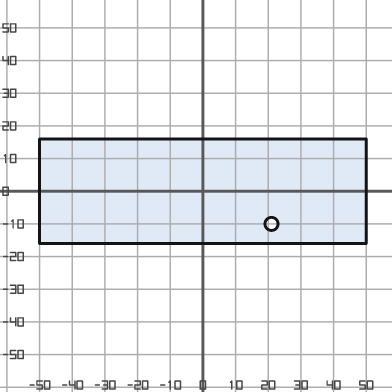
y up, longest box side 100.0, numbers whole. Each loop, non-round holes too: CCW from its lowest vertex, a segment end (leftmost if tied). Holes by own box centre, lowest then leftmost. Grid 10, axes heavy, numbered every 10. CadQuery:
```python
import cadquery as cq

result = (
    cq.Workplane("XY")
    .moveTo(-50.0, -16.0)
    .lineTo(50.0, -16.0)
    .lineTo(50.0, 16.0)
    .lineTo(-50.0, 16.0)
    .close()
    .moveTo(21.0, -10.0)
    .circle(2.0)
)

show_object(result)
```